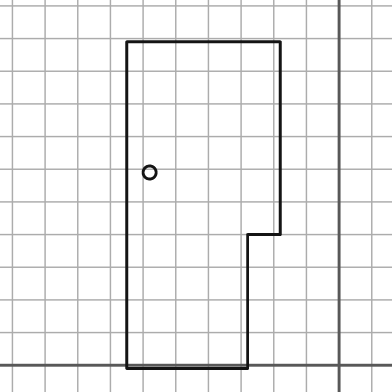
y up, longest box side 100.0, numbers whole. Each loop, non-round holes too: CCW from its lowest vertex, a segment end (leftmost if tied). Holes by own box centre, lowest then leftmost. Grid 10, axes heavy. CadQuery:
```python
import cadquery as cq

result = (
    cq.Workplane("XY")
    .moveTo(-65.0, -1.0)
    .lineTo(-28.0, -1.0)
    .lineTo(-28.0, 40.0)
    .lineTo(-18.0, 40.0)
    .lineTo(-18.0, 99.0)
    .lineTo(-65.0, 99.0)
    .close()
    .moveTo(-58.0, 59.0)
    .circle(2.0)
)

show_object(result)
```